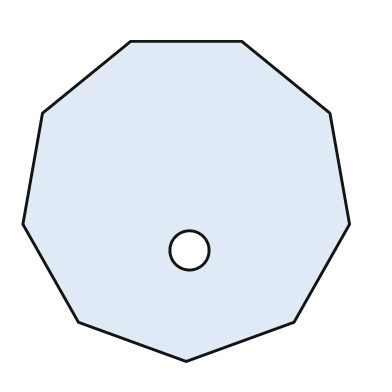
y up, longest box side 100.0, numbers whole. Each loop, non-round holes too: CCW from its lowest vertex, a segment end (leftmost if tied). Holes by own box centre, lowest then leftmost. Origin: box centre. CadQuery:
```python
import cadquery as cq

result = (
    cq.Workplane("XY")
    .moveTo(0.0, -49.0)
    .lineTo(33.0, -37.0)
    .lineTo(50.0, -7.0)
    .lineTo(44.0, 27.0)
    .lineTo(17.0, 49.0)
    .lineTo(-17.0, 49.0)
    .lineTo(-44.0, 27.0)
    .lineTo(-50.0, -7.0)
    .lineTo(-33.0, -37.0)
    .close()
    .moveTo(1.0, -15.0)
    .circle(6.0)
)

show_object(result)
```